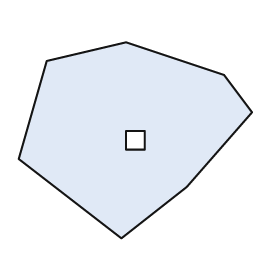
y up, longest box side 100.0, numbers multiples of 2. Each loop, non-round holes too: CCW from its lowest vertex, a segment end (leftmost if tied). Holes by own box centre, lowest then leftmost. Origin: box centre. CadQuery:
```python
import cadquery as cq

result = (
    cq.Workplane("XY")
    .moveTo(-6.0, -42.0)
    .lineTo(22.0, -20.0)
    .lineTo(50.0, 12.0)
    .lineTo(38.0, 28.0)
    .lineTo(-4.0, 42.0)
    .lineTo(-38.0, 34.0)
    .lineTo(-50.0, -8.0)
    .close()
    .moveTo(-4.0, -4.0)
    .lineTo(4.0, -4.0)
    .lineTo(4.0, 4.0)
    .lineTo(-4.0, 4.0)
    .close()
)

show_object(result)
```